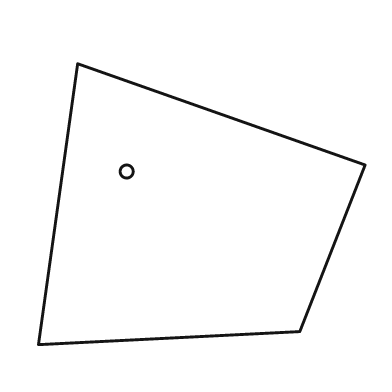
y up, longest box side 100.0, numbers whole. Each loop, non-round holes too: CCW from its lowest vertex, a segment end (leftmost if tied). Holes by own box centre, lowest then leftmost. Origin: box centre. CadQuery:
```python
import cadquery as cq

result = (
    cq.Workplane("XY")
    .moveTo(-50.0, -43.0)
    .lineTo(30.0, -39.0)
    .lineTo(50.0, 12.0)
    .lineTo(-38.0, 43.0)
    .close()
    .moveTo(-23.0, 10.0)
    .circle(2.0)
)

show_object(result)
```